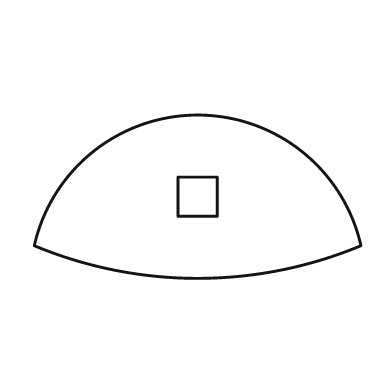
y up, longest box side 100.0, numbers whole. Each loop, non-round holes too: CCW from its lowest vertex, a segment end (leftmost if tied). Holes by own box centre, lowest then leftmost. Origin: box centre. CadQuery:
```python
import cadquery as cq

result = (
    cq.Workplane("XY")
    .moveTo(-50.0, -15.0)
    .threePointArc((0.0, -25.0), (50.0, -15.0))
    .threePointArc((0.0, 25.0), (-50.0, -15.0))
    .close()
    .moveTo(-6.0, -6.0)
    .lineTo(6.0, -6.0)
    .lineTo(6.0, 6.0)
    .lineTo(-6.0, 6.0)
    .close()
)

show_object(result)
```